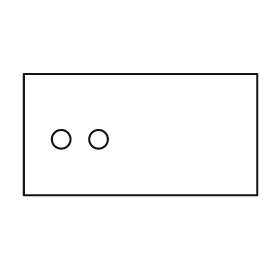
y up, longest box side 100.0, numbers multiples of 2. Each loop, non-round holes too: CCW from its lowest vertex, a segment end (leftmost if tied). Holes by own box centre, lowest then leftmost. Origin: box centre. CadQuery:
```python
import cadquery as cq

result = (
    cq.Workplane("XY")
    .moveTo(-50.0, -26.0)
    .lineTo(50.0, -26.0)
    .lineTo(50.0, 26.0)
    .lineTo(-50.0, 26.0)
    .close()
    .moveTo(-34.0, -2.0)
    .circle(4.0)
    .moveTo(-18.0, -2.0)
    .circle(4.0)
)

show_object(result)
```